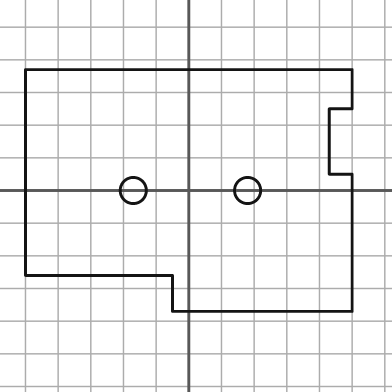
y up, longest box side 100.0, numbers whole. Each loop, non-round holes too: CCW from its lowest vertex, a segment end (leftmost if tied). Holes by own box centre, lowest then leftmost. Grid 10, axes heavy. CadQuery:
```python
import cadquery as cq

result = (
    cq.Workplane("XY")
    .moveTo(-5.0, -37.0)
    .lineTo(50.0, -37.0)
    .lineTo(50.0, 5.0)
    .lineTo(43.0, 5.0)
    .lineTo(43.0, 25.0)
    .lineTo(50.0, 25.0)
    .lineTo(50.0, 37.0)
    .lineTo(-50.0, 37.0)
    .lineTo(-50.0, -26.0)
    .lineTo(-5.0, -26.0)
    .close()
    .moveTo(-17.0, 0.0)
    .circle(4.0)
    .moveTo(18.0, 0.0)
    .circle(4.0)
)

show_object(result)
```